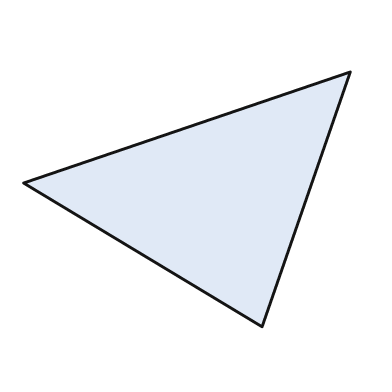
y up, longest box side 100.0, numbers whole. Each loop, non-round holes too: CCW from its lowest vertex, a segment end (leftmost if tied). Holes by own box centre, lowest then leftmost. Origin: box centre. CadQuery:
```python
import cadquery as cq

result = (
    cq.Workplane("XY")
    .moveTo(23.0, -39.0)
    .lineTo(50.0, 39.0)
    .lineTo(-50.0, 5.0)
    .close()
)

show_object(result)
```